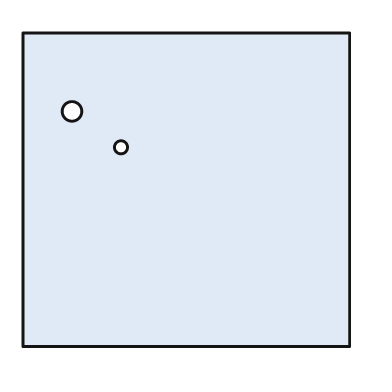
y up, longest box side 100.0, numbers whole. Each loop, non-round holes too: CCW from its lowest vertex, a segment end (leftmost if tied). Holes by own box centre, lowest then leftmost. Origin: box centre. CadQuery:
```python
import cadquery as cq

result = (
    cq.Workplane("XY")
    .moveTo(-50.0, -48.0)
    .lineTo(50.0, -48.0)
    .lineTo(50.0, 48.0)
    .lineTo(-50.0, 48.0)
    .close()
    .moveTo(-20.0, 13.0)
    .circle(2.0)
    .moveTo(-35.0, 24.0)
    .circle(3.0)
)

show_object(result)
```